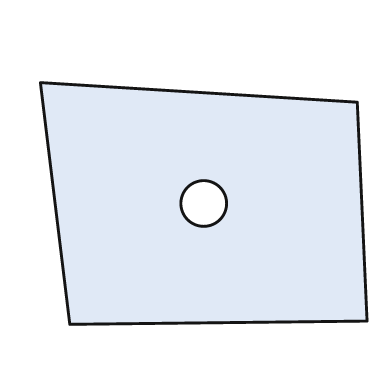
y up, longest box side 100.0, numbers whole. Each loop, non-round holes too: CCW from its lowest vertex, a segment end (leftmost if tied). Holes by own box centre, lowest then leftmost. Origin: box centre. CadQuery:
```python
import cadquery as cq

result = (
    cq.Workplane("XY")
    .moveTo(-41.0, -37.0)
    .lineTo(50.0, -36.0)
    .lineTo(47.0, 31.0)
    .lineTo(-50.0, 37.0)
    .close()
    .moveTo(0.0, 0.0)
    .circle(7.0)
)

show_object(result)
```